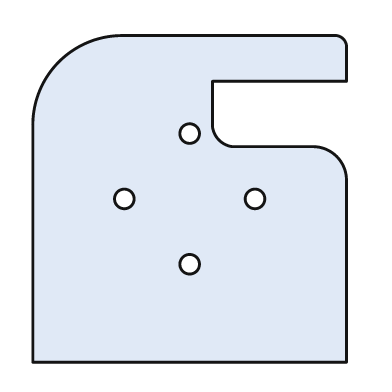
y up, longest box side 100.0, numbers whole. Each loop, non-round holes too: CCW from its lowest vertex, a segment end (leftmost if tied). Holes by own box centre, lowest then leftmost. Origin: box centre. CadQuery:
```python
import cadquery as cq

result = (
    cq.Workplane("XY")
    .moveTo(-48.0, -50.0)
    .lineTo(48.0, -50.0)
    .lineTo(48.0, 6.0)
    .threePointArc((45.0, 13.0), (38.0, 16.0))
    .lineTo(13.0, 16.0)
    .threePointArc((9.0, 18.0), (7.0, 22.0))
    .lineTo(7.0, 36.0)
    .lineTo(48.0, 36.0)
    .lineTo(48.0, 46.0)
    .threePointArc((47.0, 49.0), (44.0, 50.0))
    .lineTo(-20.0, 50.0)
    .threePointArc((-40.0, 42.0), (-48.0, 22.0))
    .close()
    .moveTo(0.0, -20.0)
    .circle(3.0)
    .moveTo(-20.0, 0.0)
    .circle(3.0)
    .moveTo(20.0, 0.0)
    .circle(3.0)
    .moveTo(0.0, 20.0)
    .circle(3.0)
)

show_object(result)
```